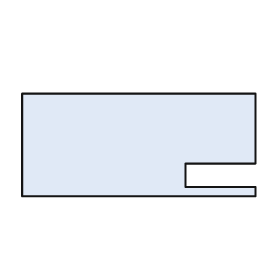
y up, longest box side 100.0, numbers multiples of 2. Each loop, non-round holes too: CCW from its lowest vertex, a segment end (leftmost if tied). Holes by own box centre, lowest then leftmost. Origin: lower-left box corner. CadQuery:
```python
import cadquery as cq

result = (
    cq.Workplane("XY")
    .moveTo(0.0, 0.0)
    .lineTo(100.0, 0.0)
    .lineTo(100.0, 4.0)
    .lineTo(70.0, 4.0)
    .lineTo(70.0, 14.0)
    .lineTo(100.0, 14.0)
    .lineTo(100.0, 44.0)
    .lineTo(0.0, 44.0)
    .close()
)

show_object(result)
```